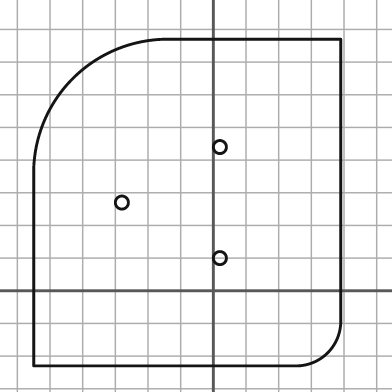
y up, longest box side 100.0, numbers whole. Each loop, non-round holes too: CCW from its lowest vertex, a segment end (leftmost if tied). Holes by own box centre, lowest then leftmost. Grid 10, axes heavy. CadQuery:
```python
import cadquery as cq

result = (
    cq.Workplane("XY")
    .moveTo(-55.0, -23.0)
    .lineTo(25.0, -23.0)
    .threePointArc((35.0, -19.0), (39.0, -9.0))
    .lineTo(39.0, 77.0)
    .lineTo(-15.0, 77.0)
    .threePointArc((-43.0, 65.0), (-55.0, 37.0))
    .close()
    .moveTo(2.0, 10.0)
    .circle(2.0)
    .moveTo(-28.0, 27.0)
    .circle(2.0)
    .moveTo(2.0, 44.0)
    .circle(2.0)
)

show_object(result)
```